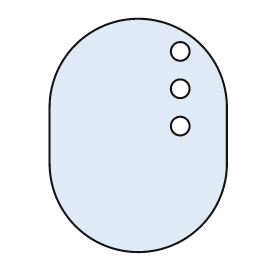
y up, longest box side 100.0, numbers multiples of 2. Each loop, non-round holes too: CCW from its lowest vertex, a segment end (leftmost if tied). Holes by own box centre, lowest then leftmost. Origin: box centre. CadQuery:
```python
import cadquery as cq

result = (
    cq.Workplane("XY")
    .moveTo(-38.0, -12.0)
    .threePointArc((0.0, -50.0), (38.0, -12.0))
    .lineTo(38.0, 12.0)
    .threePointArc((0.0, 50.0), (-38.0, 12.0))
    .close()
    .moveTo(18.0, 4.0)
    .circle(4.0)
    .moveTo(18.0, 20.0)
    .circle(4.0)
    .moveTo(18.0, 36.0)
    .circle(4.0)
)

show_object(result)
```